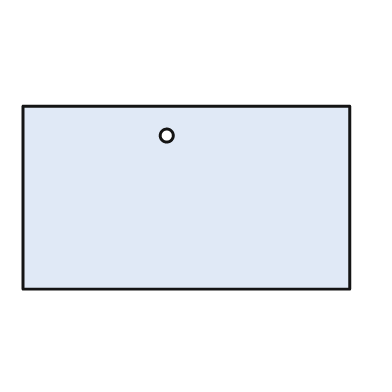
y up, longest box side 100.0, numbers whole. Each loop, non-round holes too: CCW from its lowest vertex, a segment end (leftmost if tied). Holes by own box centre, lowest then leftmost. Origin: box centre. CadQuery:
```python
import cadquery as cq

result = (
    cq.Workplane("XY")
    .moveTo(-50.0, -28.0)
    .lineTo(50.0, -28.0)
    .lineTo(50.0, 28.0)
    .lineTo(-50.0, 28.0)
    .close()
    .moveTo(-6.0, 19.0)
    .circle(2.0)
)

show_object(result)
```